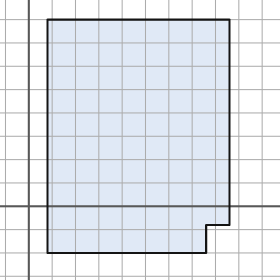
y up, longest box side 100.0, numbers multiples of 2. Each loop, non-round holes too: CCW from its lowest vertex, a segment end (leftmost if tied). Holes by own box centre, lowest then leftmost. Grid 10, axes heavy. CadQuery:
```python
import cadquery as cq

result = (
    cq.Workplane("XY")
    .moveTo(8.0, -20.0)
    .lineTo(76.0, -20.0)
    .lineTo(76.0, -8.0)
    .lineTo(86.0, -8.0)
    .lineTo(86.0, 80.0)
    .lineTo(8.0, 80.0)
    .close()
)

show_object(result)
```